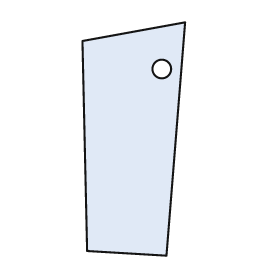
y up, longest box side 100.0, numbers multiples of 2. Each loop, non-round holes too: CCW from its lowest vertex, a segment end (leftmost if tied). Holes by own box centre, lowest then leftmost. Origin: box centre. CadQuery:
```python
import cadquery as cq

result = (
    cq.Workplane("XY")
    .moveTo(14.0, -50.0)
    .lineTo(22.0, 50.0)
    .lineTo(-22.0, 42.0)
    .lineTo(-20.0, -48.0)
    .close()
    .moveTo(12.0, 30.0)
    .circle(4.0)
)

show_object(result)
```